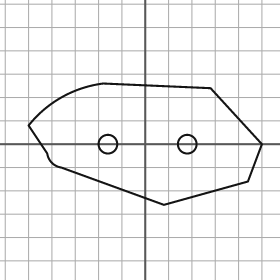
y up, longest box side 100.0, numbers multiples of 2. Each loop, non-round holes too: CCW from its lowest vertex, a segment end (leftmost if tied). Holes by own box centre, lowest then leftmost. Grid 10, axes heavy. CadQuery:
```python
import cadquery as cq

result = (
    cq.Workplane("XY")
    .moveTo(8.0, -26.0)
    .lineTo(44.0, -16.0)
    .lineTo(50.0, 0.0)
    .lineTo(28.0, 24.0)
    .lineTo(-18.0, 26.0)
    .threePointArc((-36.0, 20.0), (-50.0, 8.0))
    .lineTo(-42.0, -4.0)
    .threePointArc((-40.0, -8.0), (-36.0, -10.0))
    .close()
    .moveTo(-16.0, 0.0)
    .circle(4.0)
    .moveTo(18.0, 0.0)
    .circle(4.0)
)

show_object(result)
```